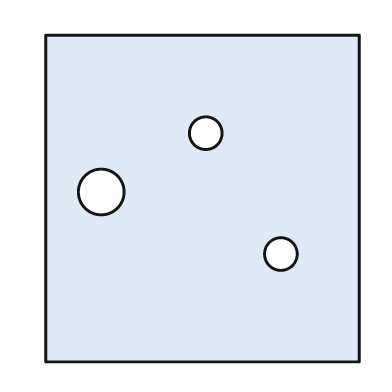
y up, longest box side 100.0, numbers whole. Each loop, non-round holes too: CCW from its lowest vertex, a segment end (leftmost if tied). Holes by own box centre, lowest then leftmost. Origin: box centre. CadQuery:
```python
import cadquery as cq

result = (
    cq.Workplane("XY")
    .moveTo(-48.0, -50.0)
    .lineTo(48.0, -50.0)
    .lineTo(48.0, 50.0)
    .lineTo(-48.0, 50.0)
    .close()
    .moveTo(24.0, -17.0)
    .circle(5.0)
    .moveTo(-31.0, 2.0)
    .circle(7.0)
    .moveTo(1.0, 20.0)
    .circle(5.0)
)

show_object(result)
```